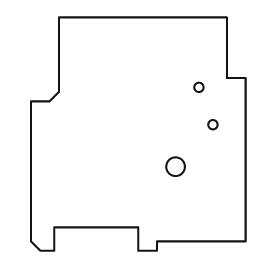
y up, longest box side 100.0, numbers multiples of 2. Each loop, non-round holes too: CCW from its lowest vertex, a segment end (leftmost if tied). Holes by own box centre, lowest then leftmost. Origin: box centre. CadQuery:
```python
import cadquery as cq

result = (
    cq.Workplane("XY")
    .moveTo(-42.0, -50.0)
    .lineTo(-36.0, -50.0)
    .lineTo(-36.0, -40.0)
    .lineTo(0.0, -40.0)
    .lineTo(0.0, -50.0)
    .lineTo(8.0, -50.0)
    .lineTo(8.0, -46.0)
    .lineTo(46.0, -46.0)
    .lineTo(46.0, 24.0)
    .lineTo(38.0, 24.0)
    .lineTo(38.0, 50.0)
    .lineTo(-34.0, 50.0)
    .lineTo(-34.0, 18.0)
    .lineTo(-38.0, 14.0)
    .lineTo(-46.0, 14.0)
    .lineTo(-46.0, -46.0)
    .close()
    .moveTo(16.0, -14.0)
    .circle(4.0)
    .moveTo(32.0, 4.0)
    .circle(2.0)
    .moveTo(26.0, 20.0)
    .circle(2.0)
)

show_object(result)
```